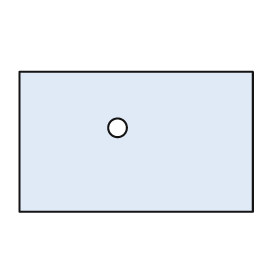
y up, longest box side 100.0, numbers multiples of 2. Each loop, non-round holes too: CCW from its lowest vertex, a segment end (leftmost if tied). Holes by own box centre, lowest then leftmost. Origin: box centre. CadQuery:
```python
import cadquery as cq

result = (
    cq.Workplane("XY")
    .moveTo(-50.0, -30.0)
    .lineTo(50.0, -30.0)
    .lineTo(50.0, 30.0)
    .lineTo(-50.0, 30.0)
    .close()
    .moveTo(-8.0, 6.0)
    .circle(4.0)
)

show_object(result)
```